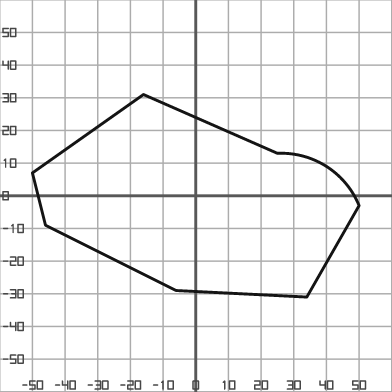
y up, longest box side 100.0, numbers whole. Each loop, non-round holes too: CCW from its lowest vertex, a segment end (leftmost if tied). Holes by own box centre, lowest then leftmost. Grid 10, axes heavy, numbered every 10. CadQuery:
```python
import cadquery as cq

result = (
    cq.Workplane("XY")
    .moveTo(34.0, -31.0)
    .lineTo(50.0, -3.0)
    .threePointArc((40.0, 9.0), (25.0, 13.0))
    .lineTo(-16.0, 31.0)
    .lineTo(-50.0, 7.0)
    .lineTo(-46.0, -9.0)
    .lineTo(-6.0, -29.0)
    .close()
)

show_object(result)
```